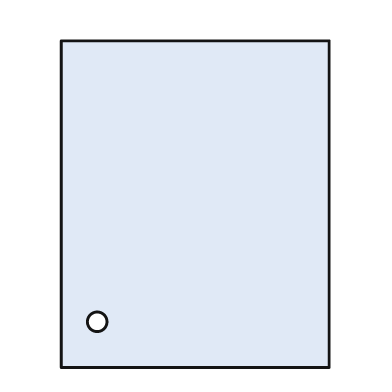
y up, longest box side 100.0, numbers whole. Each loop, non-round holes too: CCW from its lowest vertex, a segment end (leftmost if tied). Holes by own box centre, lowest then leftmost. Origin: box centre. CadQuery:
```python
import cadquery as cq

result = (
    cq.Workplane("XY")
    .moveTo(-41.0, -50.0)
    .lineTo(41.0, -50.0)
    .lineTo(41.0, 50.0)
    .lineTo(-41.0, 50.0)
    .close()
    .moveTo(-30.0, -36.0)
    .circle(3.0)
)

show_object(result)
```